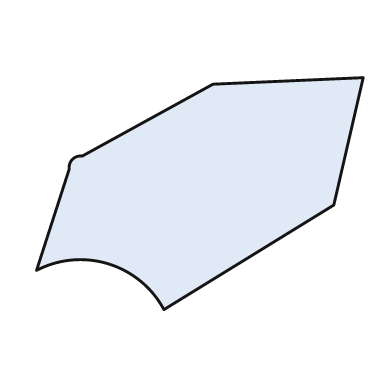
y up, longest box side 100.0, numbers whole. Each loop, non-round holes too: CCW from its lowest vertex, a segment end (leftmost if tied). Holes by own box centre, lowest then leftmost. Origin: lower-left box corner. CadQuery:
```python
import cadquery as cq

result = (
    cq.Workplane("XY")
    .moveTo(39.0, 0.0)
    .lineTo(91.0, 32.0)
    .lineTo(100.0, 71.0)
    .lineTo(54.0, 69.0)
    .lineTo(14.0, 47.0)
    .threePointArc((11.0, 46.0), (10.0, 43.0))
    .lineTo(0.0, 12.0)
    .threePointArc((22.0, 14.0), (39.0, 0.0))
    .close()
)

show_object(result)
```